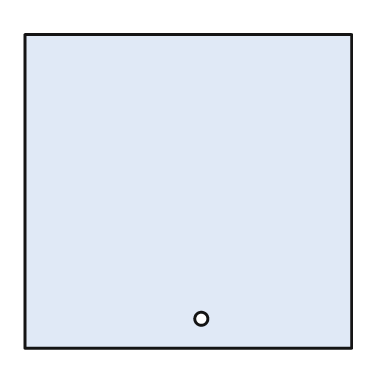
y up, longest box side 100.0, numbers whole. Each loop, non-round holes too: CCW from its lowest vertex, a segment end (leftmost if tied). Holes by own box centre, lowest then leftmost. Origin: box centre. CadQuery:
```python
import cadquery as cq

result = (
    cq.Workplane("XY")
    .moveTo(-50.0, -48.0)
    .lineTo(50.0, -48.0)
    .lineTo(50.0, 48.0)
    .lineTo(-50.0, 48.0)
    .close()
    .moveTo(4.0, -39.0)
    .circle(2.0)
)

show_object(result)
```